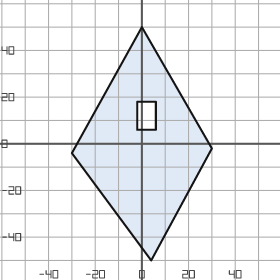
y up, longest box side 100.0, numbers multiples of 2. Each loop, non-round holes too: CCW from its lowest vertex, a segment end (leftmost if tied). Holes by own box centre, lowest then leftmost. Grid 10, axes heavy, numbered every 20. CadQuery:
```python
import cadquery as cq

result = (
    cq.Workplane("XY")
    .moveTo(4.0, -50.0)
    .lineTo(30.0, -2.0)
    .lineTo(0.0, 50.0)
    .lineTo(-30.0, -4.0)
    .close()
    .moveTo(-2.0, 6.0)
    .lineTo(6.0, 6.0)
    .lineTo(6.0, 18.0)
    .lineTo(-2.0, 18.0)
    .close()
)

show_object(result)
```